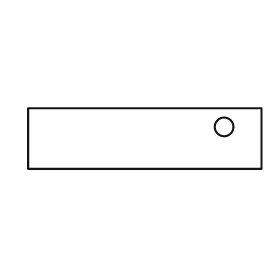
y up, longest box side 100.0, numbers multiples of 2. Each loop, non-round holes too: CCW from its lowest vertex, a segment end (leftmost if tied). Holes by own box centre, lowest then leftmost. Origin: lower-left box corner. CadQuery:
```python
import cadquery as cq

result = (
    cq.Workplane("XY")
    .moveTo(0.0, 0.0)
    .lineTo(100.0, 0.0)
    .lineTo(100.0, 26.0)
    .lineTo(0.0, 26.0)
    .close()
    .moveTo(84.0, 18.0)
    .circle(4.0)
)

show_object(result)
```